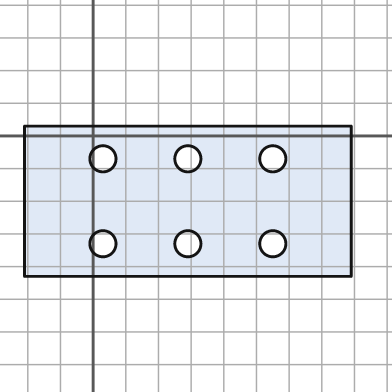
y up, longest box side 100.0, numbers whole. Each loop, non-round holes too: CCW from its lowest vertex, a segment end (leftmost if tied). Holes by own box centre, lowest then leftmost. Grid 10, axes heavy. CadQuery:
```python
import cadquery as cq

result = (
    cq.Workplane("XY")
    .moveTo(-21.0, -43.0)
    .lineTo(79.0, -43.0)
    .lineTo(79.0, 3.0)
    .lineTo(-21.0, 3.0)
    .close()
    .moveTo(3.0, -33.0)
    .circle(4.0)
    .moveTo(29.0, -33.0)
    .circle(4.0)
    .moveTo(55.0, -33.0)
    .circle(4.0)
    .moveTo(3.0, -7.0)
    .circle(4.0)
    .moveTo(29.0, -7.0)
    .circle(4.0)
    .moveTo(55.0, -7.0)
    .circle(4.0)
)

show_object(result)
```